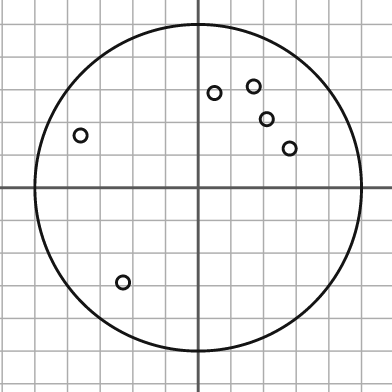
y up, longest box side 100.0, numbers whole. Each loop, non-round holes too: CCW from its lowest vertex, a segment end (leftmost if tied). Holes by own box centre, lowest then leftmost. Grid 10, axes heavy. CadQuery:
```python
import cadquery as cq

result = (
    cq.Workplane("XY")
    .moveTo(0.0, 0.0)
    .circle(50.0)
    .moveTo(-23.0, -29.0)
    .circle(2.0)
    .moveTo(28.0, 12.0)
    .circle(2.0)
    .moveTo(-36.0, 16.0)
    .circle(2.0)
    .moveTo(21.0, 21.0)
    .circle(2.0)
    .moveTo(5.0, 29.0)
    .circle(2.0)
    .moveTo(17.0, 31.0)
    .circle(2.0)
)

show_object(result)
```